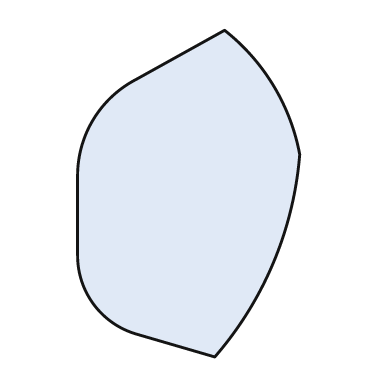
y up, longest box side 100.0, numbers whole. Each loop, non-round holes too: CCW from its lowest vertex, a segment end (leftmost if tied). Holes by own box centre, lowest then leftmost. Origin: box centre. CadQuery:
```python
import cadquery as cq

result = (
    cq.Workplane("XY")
    .moveTo(8.0, -50.0)
    .threePointArc((26.0, -21.0), (34.0, 12.0))
    .threePointArc((26.0, 33.0), (11.0, 50.0))
    .lineTo(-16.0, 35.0)
    .threePointArc((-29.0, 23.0), (-34.0, 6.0))
    .lineTo(-34.0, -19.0)
    .threePointArc((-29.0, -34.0), (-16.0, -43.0))
    .close()
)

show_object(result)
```